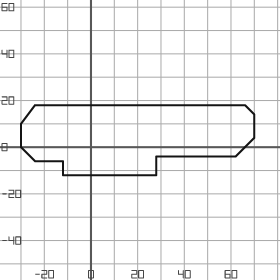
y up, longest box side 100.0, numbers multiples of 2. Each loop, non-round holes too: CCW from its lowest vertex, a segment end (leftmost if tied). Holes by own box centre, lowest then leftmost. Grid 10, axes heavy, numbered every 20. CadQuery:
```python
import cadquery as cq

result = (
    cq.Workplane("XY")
    .moveTo(-12.0, -12.0)
    .lineTo(28.0, -12.0)
    .lineTo(28.0, -4.0)
    .lineTo(62.0, -4.0)
    .lineTo(70.0, 4.0)
    .lineTo(70.0, 14.0)
    .lineTo(66.0, 18.0)
    .lineTo(-24.0, 18.0)
    .lineTo(-30.0, 10.0)
    .lineTo(-30.0, 0.0)
    .lineTo(-24.0, -6.0)
    .lineTo(-12.0, -6.0)
    .close()
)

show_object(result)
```